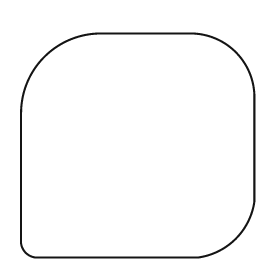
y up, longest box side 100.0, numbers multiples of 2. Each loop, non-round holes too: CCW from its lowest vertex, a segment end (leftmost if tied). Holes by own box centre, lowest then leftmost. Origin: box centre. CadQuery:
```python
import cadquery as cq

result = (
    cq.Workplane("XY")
    .moveTo(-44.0, -48.0)
    .lineTo(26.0, -48.0)
    .threePointArc((42.0, -40.0), (50.0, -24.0))
    .lineTo(50.0, 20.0)
    .threePointArc((42.0, 40.0), (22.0, 48.0))
    .lineTo(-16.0, 48.0)
    .threePointArc((-40.0, 38.0), (-50.0, 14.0))
    .lineTo(-50.0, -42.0)
    .threePointArc((-48.0, -46.0), (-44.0, -48.0))
    .close()
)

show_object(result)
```